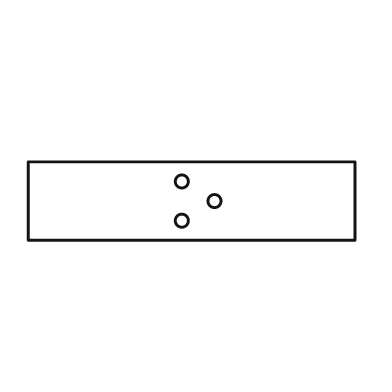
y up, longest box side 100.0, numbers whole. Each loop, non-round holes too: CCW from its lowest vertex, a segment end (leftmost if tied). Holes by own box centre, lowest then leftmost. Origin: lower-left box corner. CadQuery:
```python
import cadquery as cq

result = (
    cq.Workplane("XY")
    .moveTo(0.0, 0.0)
    .lineTo(100.0, 0.0)
    .lineTo(100.0, 24.0)
    .lineTo(0.0, 24.0)
    .close()
    .moveTo(47.0, 6.0)
    .circle(2.0)
    .moveTo(57.0, 12.0)
    .circle(2.0)
    .moveTo(47.0, 18.0)
    .circle(2.0)
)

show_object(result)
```